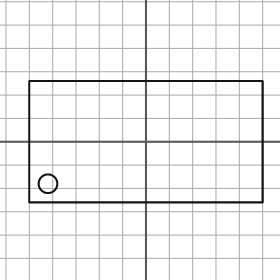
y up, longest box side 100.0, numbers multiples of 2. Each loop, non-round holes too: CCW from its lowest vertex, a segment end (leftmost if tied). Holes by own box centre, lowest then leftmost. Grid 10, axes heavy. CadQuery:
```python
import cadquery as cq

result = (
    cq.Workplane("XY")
    .moveTo(-50.0, -26.0)
    .lineTo(50.0, -26.0)
    .lineTo(50.0, 26.0)
    .lineTo(-50.0, 26.0)
    .close()
    .moveTo(-42.0, -18.0)
    .circle(4.0)
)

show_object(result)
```